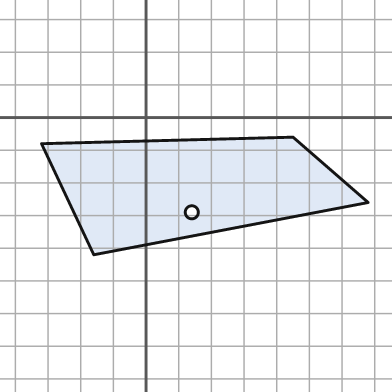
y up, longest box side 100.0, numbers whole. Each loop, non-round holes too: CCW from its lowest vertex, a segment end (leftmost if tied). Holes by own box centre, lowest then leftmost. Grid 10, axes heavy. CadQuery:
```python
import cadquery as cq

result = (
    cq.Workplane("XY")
    .moveTo(-16.0, -42.0)
    .lineTo(68.0, -26.0)
    .lineTo(45.0, -6.0)
    .lineTo(-32.0, -8.0)
    .close()
    .moveTo(14.0, -29.0)
    .circle(2.0)
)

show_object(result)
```